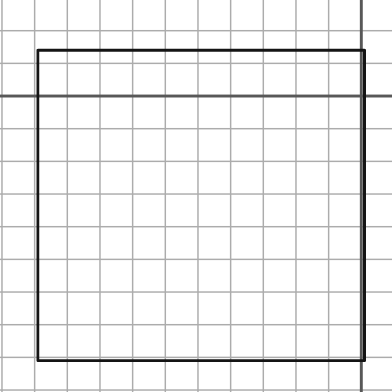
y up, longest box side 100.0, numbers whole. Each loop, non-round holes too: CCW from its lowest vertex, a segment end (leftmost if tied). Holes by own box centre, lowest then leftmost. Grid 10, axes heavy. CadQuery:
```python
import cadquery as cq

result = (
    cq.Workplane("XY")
    .moveTo(-99.0, -81.0)
    .lineTo(1.0, -81.0)
    .lineTo(1.0, 14.0)
    .lineTo(-99.0, 14.0)
    .close()
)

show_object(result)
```